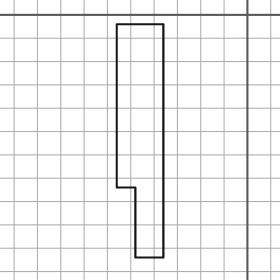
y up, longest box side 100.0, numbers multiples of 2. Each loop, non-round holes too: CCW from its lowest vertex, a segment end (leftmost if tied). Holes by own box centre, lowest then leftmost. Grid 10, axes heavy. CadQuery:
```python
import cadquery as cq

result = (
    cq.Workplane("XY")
    .moveTo(-48.0, -104.0)
    .lineTo(-36.0, -104.0)
    .lineTo(-36.0, -4.0)
    .lineTo(-56.0, -4.0)
    .lineTo(-56.0, -74.0)
    .lineTo(-48.0, -74.0)
    .close()
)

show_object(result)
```